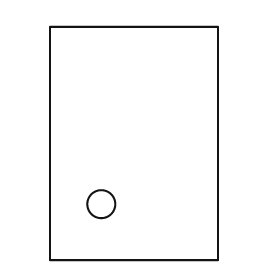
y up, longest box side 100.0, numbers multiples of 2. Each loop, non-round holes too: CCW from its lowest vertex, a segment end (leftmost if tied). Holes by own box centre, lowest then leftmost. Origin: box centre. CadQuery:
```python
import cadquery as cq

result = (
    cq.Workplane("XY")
    .moveTo(-36.0, -50.0)
    .lineTo(36.0, -50.0)
    .lineTo(36.0, 50.0)
    .lineTo(-36.0, 50.0)
    .close()
    .moveTo(-14.0, -26.0)
    .circle(6.0)
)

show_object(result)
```